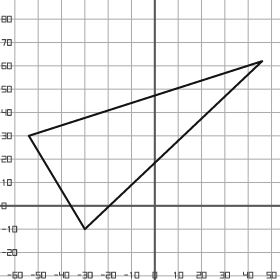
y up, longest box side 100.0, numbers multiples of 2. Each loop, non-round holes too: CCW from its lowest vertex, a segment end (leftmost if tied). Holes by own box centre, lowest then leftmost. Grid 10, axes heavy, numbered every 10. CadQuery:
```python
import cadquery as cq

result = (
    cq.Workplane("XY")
    .moveTo(-30.0, -10.0)
    .lineTo(46.0, 62.0)
    .lineTo(-54.0, 30.0)
    .close()
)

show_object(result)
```